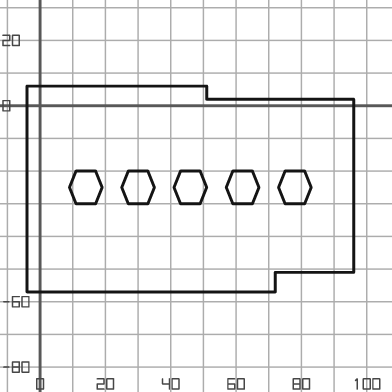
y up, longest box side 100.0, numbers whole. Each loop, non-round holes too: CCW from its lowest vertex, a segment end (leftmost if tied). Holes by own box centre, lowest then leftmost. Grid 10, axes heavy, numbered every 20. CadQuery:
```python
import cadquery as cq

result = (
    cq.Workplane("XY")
    .moveTo(-4.0, -57.0)
    .lineTo(72.0, -57.0)
    .lineTo(72.0, -51.0)
    .lineTo(96.0, -51.0)
    .lineTo(96.0, 2.0)
    .lineTo(51.0, 2.0)
    .lineTo(51.0, 6.0)
    .lineTo(-4.0, 6.0)
    .close()
    .moveTo(11.0, -30.0)
    .lineTo(17.0, -30.0)
    .lineTo(19.0, -25.0)
    .lineTo(17.0, -20.0)
    .lineTo(11.0, -20.0)
    .lineTo(9.0, -25.0)
    .close()
    .moveTo(27.0, -30.0)
    .lineTo(33.0, -30.0)
    .lineTo(35.0, -25.0)
    .lineTo(33.0, -20.0)
    .lineTo(27.0, -20.0)
    .lineTo(25.0, -25.0)
    .close()
    .moveTo(43.0, -30.0)
    .lineTo(49.0, -30.0)
    .lineTo(51.0, -25.0)
    .lineTo(49.0, -20.0)
    .lineTo(43.0, -20.0)
    .lineTo(41.0, -25.0)
    .close()
    .moveTo(59.0, -30.0)
    .lineTo(65.0, -30.0)
    .lineTo(67.0, -25.0)
    .lineTo(65.0, -20.0)
    .lineTo(59.0, -20.0)
    .lineTo(57.0, -25.0)
    .close()
    .moveTo(75.0, -30.0)
    .lineTo(81.0, -30.0)
    .lineTo(83.0, -25.0)
    .lineTo(81.0, -20.0)
    .lineTo(75.0, -20.0)
    .lineTo(73.0, -25.0)
    .close()
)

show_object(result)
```